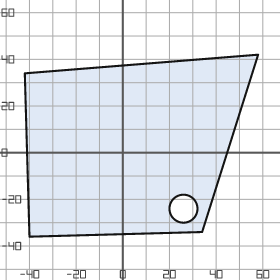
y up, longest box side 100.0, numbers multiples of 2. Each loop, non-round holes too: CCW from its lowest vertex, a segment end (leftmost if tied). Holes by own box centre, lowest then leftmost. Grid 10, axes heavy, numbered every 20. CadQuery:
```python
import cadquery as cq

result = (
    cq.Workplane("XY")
    .moveTo(-40.0, -36.0)
    .lineTo(34.0, -34.0)
    .lineTo(58.0, 42.0)
    .lineTo(-42.0, 34.0)
    .close()
    .moveTo(26.0, -24.0)
    .circle(6.0)
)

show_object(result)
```